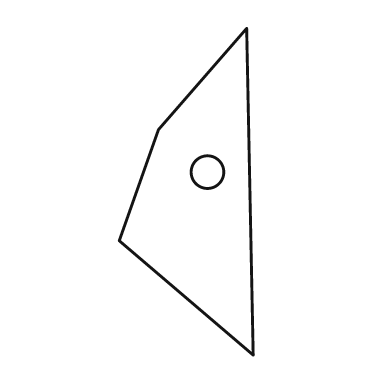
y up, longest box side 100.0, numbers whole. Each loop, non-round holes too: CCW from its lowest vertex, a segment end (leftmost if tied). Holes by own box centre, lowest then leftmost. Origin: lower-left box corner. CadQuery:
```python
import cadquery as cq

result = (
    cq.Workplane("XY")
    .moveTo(41.0, 0.0)
    .lineTo(39.0, 100.0)
    .lineTo(12.0, 69.0)
    .lineTo(0.0, 35.0)
    .close()
    .moveTo(27.0, 56.0)
    .circle(5.0)
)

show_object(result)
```